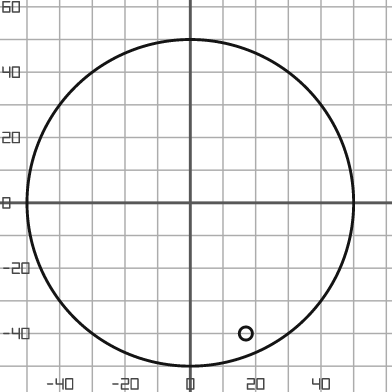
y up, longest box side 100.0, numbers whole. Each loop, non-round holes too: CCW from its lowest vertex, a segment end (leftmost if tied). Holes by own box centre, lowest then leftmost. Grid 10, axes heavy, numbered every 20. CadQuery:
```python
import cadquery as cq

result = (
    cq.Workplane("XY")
    .moveTo(0.0, 0.0)
    .circle(50.0)
    .moveTo(17.0, -40.0)
    .circle(2.0)
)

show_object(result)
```